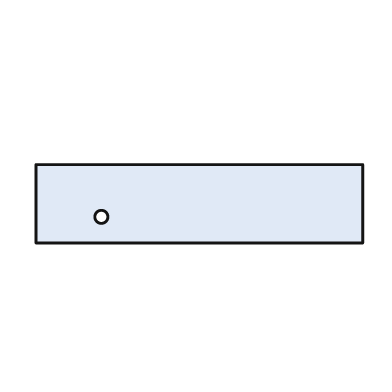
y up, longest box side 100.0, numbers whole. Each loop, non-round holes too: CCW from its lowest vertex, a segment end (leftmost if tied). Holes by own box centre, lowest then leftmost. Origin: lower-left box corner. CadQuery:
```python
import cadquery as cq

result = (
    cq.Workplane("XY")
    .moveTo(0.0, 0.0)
    .lineTo(100.0, 0.0)
    .lineTo(100.0, 24.0)
    .lineTo(0.0, 24.0)
    .close()
    .moveTo(20.0, 8.0)
    .circle(2.0)
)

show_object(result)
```